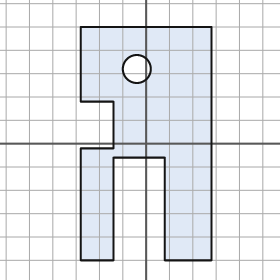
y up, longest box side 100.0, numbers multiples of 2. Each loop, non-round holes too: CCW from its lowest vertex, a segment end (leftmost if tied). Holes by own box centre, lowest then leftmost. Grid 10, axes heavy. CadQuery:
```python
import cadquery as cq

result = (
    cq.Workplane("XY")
    .moveTo(-28.0, -50.0)
    .lineTo(-14.0, -50.0)
    .lineTo(-14.0, -6.0)
    .lineTo(8.0, -6.0)
    .lineTo(8.0, -50.0)
    .lineTo(28.0, -50.0)
    .lineTo(28.0, 50.0)
    .lineTo(-28.0, 50.0)
    .lineTo(-28.0, 18.0)
    .lineTo(-14.0, 18.0)
    .lineTo(-14.0, -2.0)
    .lineTo(-28.0, -2.0)
    .close()
    .moveTo(-4.0, 32.0)
    .circle(6.0)
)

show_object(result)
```